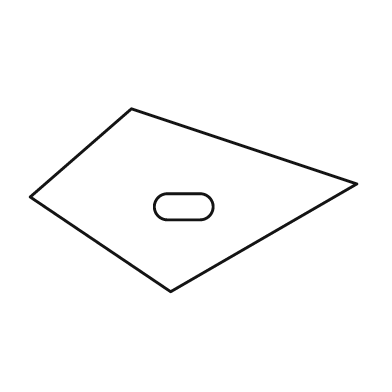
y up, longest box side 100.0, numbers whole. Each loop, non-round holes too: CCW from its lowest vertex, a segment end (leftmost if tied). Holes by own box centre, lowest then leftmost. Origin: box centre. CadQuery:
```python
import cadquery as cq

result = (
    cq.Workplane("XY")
    .moveTo(-7.0, -28.0)
    .lineTo(50.0, 5.0)
    .lineTo(-19.0, 28.0)
    .lineTo(-50.0, 1.0)
    .close()
    .moveTo(-8.0, -6.0)
    .lineTo(2.0, -6.0)
    .threePointArc((6.0, -2.0), (2.0, 2.0))
    .lineTo(-8.0, 2.0)
    .threePointArc((-12.0, -2.0), (-8.0, -6.0))
    .close()
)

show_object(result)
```